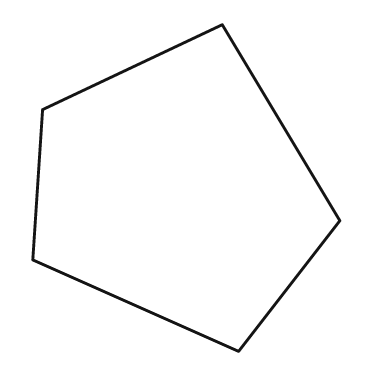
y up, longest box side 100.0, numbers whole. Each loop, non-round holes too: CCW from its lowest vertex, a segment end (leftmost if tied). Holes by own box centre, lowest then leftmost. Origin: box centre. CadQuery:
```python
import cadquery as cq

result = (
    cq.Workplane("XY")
    .moveTo(16.0, -50.0)
    .lineTo(47.0, -10.0)
    .lineTo(11.0, 50.0)
    .lineTo(-44.0, 24.0)
    .lineTo(-47.0, -22.0)
    .close()
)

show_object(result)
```